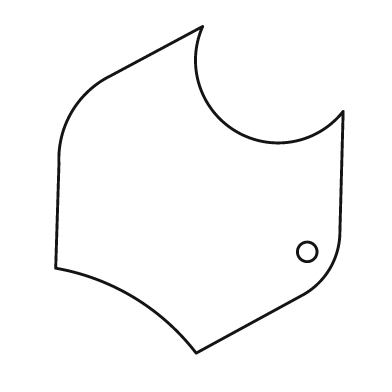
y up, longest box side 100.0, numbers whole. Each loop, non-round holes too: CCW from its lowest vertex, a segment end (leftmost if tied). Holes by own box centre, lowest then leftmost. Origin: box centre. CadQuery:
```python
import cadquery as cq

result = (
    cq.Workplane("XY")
    .moveTo(-1.0, -50.0)
    .lineTo(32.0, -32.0)
    .threePointArc((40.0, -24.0), (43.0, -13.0))
    .lineTo(44.0, 24.0)
    .threePointArc((11.0, 18.0), (1.0, 50.0))
    .lineTo(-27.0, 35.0)
    .threePointArc((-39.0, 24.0), (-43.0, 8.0))
    .lineTo(-44.0, -24.0)
    .threePointArc((-20.0, -33.0), (-1.0, -50.0))
    .close()
    .moveTo(33.0, -19.0)
    .circle(3.0)
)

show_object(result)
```